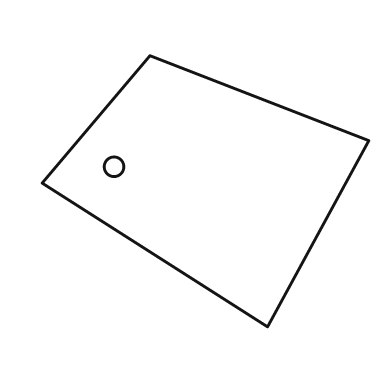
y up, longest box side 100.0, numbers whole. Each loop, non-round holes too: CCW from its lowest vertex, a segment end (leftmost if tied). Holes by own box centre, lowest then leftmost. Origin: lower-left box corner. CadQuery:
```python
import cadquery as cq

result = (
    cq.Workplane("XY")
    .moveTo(69.0, 0.0)
    .lineTo(100.0, 57.0)
    .lineTo(33.0, 83.0)
    .lineTo(0.0, 44.0)
    .close()
    .moveTo(22.0, 49.0)
    .circle(3.0)
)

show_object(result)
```